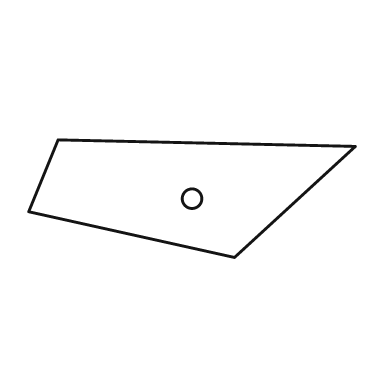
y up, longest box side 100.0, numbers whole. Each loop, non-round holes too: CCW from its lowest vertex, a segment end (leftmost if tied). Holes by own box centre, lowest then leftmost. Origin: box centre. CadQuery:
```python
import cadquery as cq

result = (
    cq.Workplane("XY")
    .moveTo(13.0, -18.0)
    .lineTo(50.0, 16.0)
    .lineTo(-41.0, 18.0)
    .lineTo(-50.0, -4.0)
    .close()
    .moveTo(0.0, 0.0)
    .circle(3.0)
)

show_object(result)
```